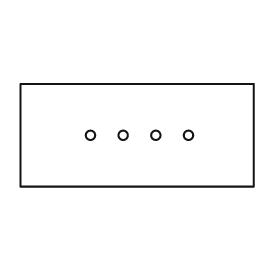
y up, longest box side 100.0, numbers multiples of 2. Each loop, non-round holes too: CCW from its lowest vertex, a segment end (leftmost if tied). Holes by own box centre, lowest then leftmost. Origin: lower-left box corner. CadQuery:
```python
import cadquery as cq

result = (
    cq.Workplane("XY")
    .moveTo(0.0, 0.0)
    .lineTo(100.0, 0.0)
    .lineTo(100.0, 44.0)
    .lineTo(0.0, 44.0)
    .close()
    .moveTo(30.0, 22.0)
    .circle(2.0)
    .moveTo(44.0, 22.0)
    .circle(2.0)
    .moveTo(58.0, 22.0)
    .circle(2.0)
    .moveTo(72.0, 22.0)
    .circle(2.0)
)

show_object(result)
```